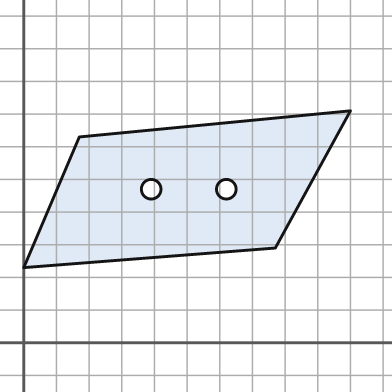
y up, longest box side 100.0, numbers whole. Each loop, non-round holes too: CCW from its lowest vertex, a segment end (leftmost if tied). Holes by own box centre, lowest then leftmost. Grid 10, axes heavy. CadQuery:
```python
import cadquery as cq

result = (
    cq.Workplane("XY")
    .moveTo(0.0, 23.0)
    .lineTo(77.0, 29.0)
    .lineTo(100.0, 71.0)
    .lineTo(17.0, 63.0)
    .close()
    .moveTo(39.0, 47.0)
    .circle(3.0)
    .moveTo(62.0, 47.0)
    .circle(3.0)
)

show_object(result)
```